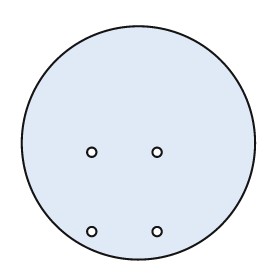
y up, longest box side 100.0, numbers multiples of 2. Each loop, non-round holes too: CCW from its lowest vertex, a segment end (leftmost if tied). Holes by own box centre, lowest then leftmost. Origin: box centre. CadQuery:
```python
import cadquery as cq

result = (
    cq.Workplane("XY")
    .moveTo(0.0, 0.0)
    .circle(50.0)
    .moveTo(-20.0, -38.0)
    .circle(2.0)
    .moveTo(8.0, -38.0)
    .circle(2.0)
    .moveTo(-20.0, -4.0)
    .circle(2.0)
    .moveTo(8.0, -4.0)
    .circle(2.0)
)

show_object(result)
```